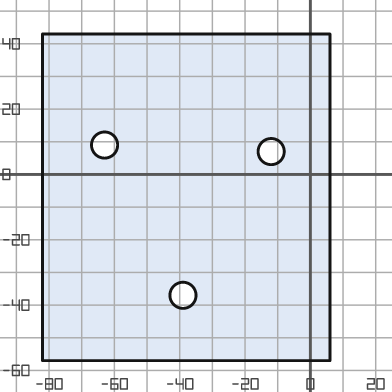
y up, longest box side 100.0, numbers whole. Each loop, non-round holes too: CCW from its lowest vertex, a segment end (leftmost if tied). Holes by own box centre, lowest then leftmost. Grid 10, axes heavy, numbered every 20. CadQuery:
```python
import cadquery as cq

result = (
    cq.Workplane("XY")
    .moveTo(-82.0, -57.0)
    .lineTo(6.0, -57.0)
    .lineTo(6.0, 43.0)
    .lineTo(-82.0, 43.0)
    .close()
    .moveTo(-39.0, -37.0)
    .circle(4.0)
    .moveTo(-12.0, 7.0)
    .circle(4.0)
    .moveTo(-63.0, 9.0)
    .circle(4.0)
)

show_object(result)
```